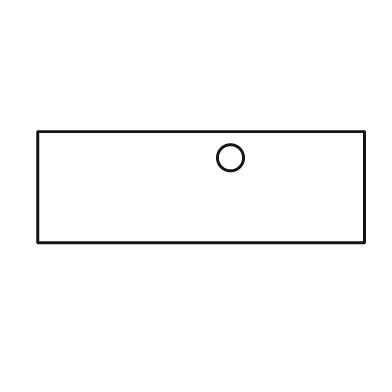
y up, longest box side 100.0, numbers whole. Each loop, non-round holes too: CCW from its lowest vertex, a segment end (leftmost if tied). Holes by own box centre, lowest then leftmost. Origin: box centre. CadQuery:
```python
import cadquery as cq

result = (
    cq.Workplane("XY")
    .moveTo(-50.0, -17.0)
    .lineTo(50.0, -17.0)
    .lineTo(50.0, 17.0)
    .lineTo(-50.0, 17.0)
    .close()
    .moveTo(9.0, 9.0)
    .circle(4.0)
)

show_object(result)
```